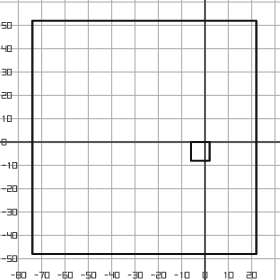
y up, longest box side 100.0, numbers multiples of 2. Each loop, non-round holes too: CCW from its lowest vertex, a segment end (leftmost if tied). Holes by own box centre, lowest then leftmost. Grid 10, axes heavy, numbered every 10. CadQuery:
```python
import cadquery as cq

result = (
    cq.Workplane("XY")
    .moveTo(-74.0, -48.0)
    .lineTo(22.0, -48.0)
    .lineTo(22.0, 52.0)
    .lineTo(-74.0, 52.0)
    .close()
    .moveTo(-6.0, -8.0)
    .lineTo(2.0, -8.0)
    .lineTo(2.0, 0.0)
    .lineTo(-6.0, 0.0)
    .close()
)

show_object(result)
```